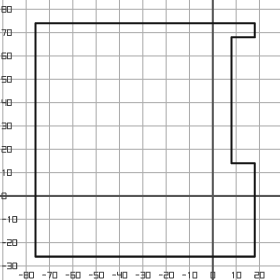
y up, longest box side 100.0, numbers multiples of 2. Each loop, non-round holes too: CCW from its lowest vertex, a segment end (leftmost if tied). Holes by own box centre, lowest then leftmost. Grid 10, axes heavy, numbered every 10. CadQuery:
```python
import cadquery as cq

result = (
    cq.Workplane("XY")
    .moveTo(-76.0, -26.0)
    .lineTo(18.0, -26.0)
    .lineTo(18.0, 14.0)
    .lineTo(8.0, 14.0)
    .lineTo(8.0, 68.0)
    .lineTo(18.0, 68.0)
    .lineTo(18.0, 74.0)
    .lineTo(-76.0, 74.0)
    .close()
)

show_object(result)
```